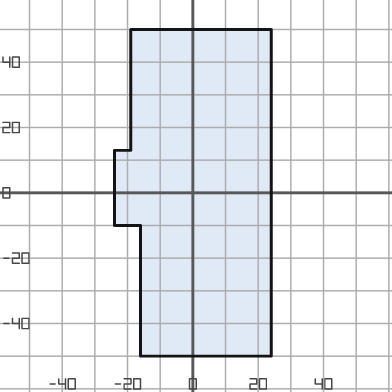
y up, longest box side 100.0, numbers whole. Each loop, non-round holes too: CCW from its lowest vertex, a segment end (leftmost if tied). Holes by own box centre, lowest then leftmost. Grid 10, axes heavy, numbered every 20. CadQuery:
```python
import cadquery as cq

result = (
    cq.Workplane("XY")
    .moveTo(-16.0, -50.0)
    .lineTo(24.0, -50.0)
    .lineTo(24.0, 50.0)
    .lineTo(-19.0, 50.0)
    .lineTo(-19.0, 13.0)
    .lineTo(-24.0, 13.0)
    .lineTo(-24.0, -10.0)
    .lineTo(-16.0, -10.0)
    .close()
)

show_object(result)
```